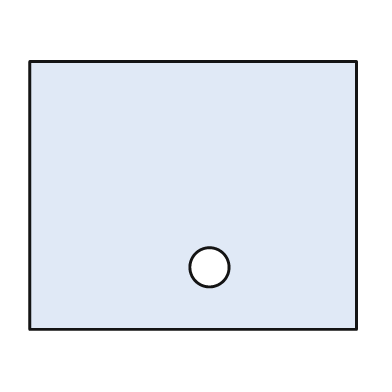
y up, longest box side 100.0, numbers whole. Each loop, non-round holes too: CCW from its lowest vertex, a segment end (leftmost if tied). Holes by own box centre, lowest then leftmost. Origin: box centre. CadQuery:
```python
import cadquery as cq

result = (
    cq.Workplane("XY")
    .moveTo(-50.0, -41.0)
    .lineTo(50.0, -41.0)
    .lineTo(50.0, 41.0)
    .lineTo(-50.0, 41.0)
    .close()
    .moveTo(5.0, -22.0)
    .circle(6.0)
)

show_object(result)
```